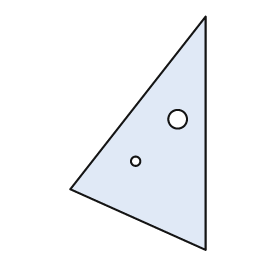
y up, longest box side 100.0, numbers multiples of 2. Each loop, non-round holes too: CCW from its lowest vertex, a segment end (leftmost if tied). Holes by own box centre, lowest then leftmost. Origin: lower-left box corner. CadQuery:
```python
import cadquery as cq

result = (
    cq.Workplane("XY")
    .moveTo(58.0, 0.0)
    .lineTo(58.0, 100.0)
    .lineTo(0.0, 26.0)
    .close()
    .moveTo(28.0, 38.0)
    .circle(2.0)
    .moveTo(46.0, 56.0)
    .circle(4.0)
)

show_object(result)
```